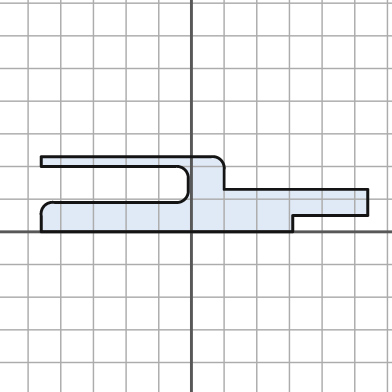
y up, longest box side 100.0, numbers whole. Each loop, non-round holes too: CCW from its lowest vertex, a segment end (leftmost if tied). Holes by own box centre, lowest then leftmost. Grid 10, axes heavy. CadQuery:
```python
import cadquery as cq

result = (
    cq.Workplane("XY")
    .moveTo(-46.0, 0.0)
    .lineTo(31.0, 0.0)
    .lineTo(31.0, 5.0)
    .lineTo(54.0, 5.0)
    .lineTo(54.0, 13.0)
    .lineTo(10.0, 13.0)
    .lineTo(10.0, 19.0)
    .threePointArc((9.0, 22.0), (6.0, 23.0))
    .lineTo(-46.0, 23.0)
    .lineTo(-46.0, 20.0)
    .lineTo(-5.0, 20.0)
    .threePointArc((-2.0, 19.0), (-1.0, 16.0))
    .lineTo(-1.0, 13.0)
    .threePointArc((-2.0, 10.0), (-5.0, 9.0))
    .lineTo(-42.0, 9.0)
    .threePointArc((-45.0, 8.0), (-46.0, 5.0))
    .close()
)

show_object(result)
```